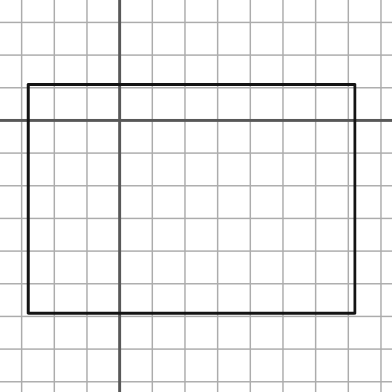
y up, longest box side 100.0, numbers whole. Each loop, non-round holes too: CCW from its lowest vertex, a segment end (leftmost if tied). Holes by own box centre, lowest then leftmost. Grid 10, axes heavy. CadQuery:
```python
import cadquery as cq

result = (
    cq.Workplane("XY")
    .moveTo(-28.0, -59.0)
    .lineTo(72.0, -59.0)
    .lineTo(72.0, 11.0)
    .lineTo(-28.0, 11.0)
    .close()
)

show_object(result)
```